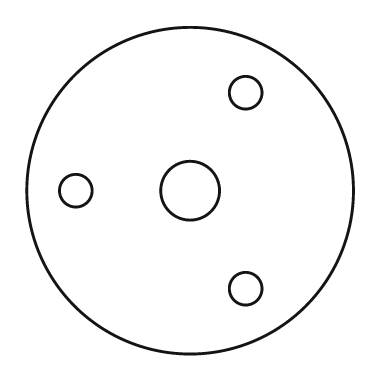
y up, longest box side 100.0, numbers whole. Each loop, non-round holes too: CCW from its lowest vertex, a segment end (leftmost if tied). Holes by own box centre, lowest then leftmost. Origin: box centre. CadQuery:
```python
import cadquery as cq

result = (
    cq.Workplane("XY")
    .moveTo(0.0, 0.0)
    .circle(50.0)
    .moveTo(17.0, -30.0)
    .circle(5.0)
    .moveTo(-35.0, 0.0)
    .circle(5.0)
    .moveTo(0.0, 0.0)
    .circle(9.0)
    .moveTo(17.0, 30.0)
    .circle(5.0)
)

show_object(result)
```